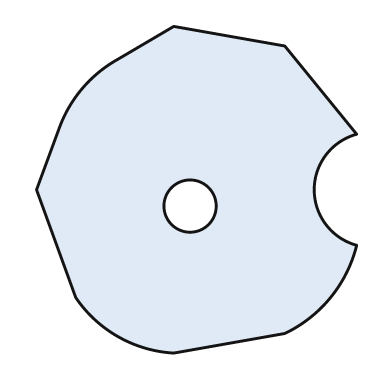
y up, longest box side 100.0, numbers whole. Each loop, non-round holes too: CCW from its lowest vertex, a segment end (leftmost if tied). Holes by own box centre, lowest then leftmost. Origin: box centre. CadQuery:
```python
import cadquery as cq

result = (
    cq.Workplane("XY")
    .moveTo(-7.0, -50.0)
    .lineTo(27.0, -44.0)
    .threePointArc((41.0, -33.0), (49.0, -17.0))
    .threePointArc((36.0, 0.0), (49.0, 17.0))
    .lineTo(27.0, 44.0)
    .lineTo(-7.0, 50.0)
    .lineTo(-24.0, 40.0)
    .threePointArc((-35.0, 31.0), (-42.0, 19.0))
    .lineTo(-49.0, 0.0)
    .lineTo(-37.0, -33.0)
    .threePointArc((-24.0, -45.0), (-7.0, -50.0))
    .close()
    .moveTo(-2.0, -5.0)
    .circle(8.0)
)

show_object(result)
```